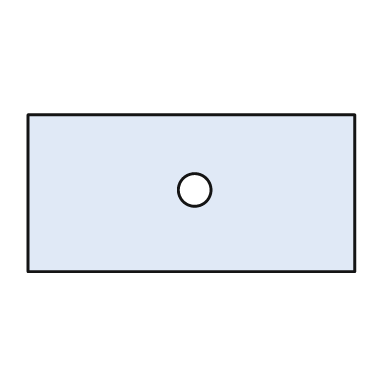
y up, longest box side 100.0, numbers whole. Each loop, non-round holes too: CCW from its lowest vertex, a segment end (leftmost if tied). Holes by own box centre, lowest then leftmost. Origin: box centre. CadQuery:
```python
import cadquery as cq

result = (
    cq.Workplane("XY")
    .moveTo(-50.0, -24.0)
    .lineTo(50.0, -24.0)
    .lineTo(50.0, 24.0)
    .lineTo(-50.0, 24.0)
    .close()
    .moveTo(1.0, 1.0)
    .circle(5.0)
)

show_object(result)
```